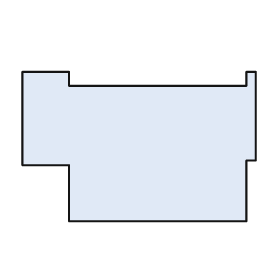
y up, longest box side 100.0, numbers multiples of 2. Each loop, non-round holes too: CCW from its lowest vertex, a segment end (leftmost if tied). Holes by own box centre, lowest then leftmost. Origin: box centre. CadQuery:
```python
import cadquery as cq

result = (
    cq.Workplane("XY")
    .moveTo(-30.0, -32.0)
    .lineTo(46.0, -32.0)
    .lineTo(46.0, -6.0)
    .lineTo(50.0, -6.0)
    .lineTo(50.0, 32.0)
    .lineTo(46.0, 32.0)
    .lineTo(46.0, 26.0)
    .lineTo(-30.0, 26.0)
    .lineTo(-30.0, 32.0)
    .lineTo(-50.0, 32.0)
    .lineTo(-50.0, -8.0)
    .lineTo(-30.0, -8.0)
    .close()
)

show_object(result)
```